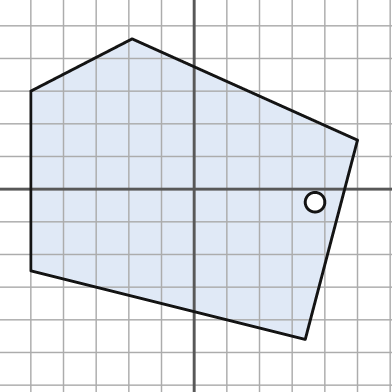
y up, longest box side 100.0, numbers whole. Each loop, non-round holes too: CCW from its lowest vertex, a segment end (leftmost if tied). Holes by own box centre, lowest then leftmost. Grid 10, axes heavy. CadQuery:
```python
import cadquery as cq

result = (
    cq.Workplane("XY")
    .moveTo(34.0, -46.0)
    .lineTo(50.0, 15.0)
    .lineTo(-19.0, 46.0)
    .lineTo(-50.0, 30.0)
    .lineTo(-50.0, -25.0)
    .close()
    .moveTo(37.0, -4.0)
    .circle(3.0)
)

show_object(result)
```